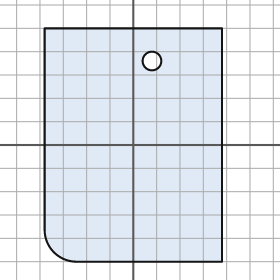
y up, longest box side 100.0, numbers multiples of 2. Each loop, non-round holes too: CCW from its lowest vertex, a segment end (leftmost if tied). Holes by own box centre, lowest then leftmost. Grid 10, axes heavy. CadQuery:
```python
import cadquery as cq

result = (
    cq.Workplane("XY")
    .moveTo(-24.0, -50.0)
    .lineTo(38.0, -50.0)
    .lineTo(38.0, 50.0)
    .lineTo(-38.0, 50.0)
    .lineTo(-38.0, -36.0)
    .threePointArc((-34.0, -46.0), (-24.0, -50.0))
    .close()
    .moveTo(8.0, 36.0)
    .circle(4.0)
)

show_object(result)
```